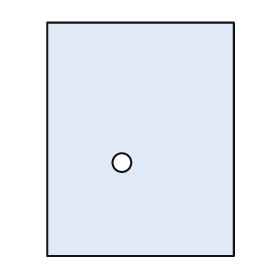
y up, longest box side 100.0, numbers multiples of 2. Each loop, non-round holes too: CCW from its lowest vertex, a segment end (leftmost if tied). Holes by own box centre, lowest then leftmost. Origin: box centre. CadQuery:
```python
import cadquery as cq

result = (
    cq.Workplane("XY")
    .moveTo(-40.0, -50.0)
    .lineTo(40.0, -50.0)
    .lineTo(40.0, 50.0)
    .lineTo(-40.0, 50.0)
    .close()
    .moveTo(-8.0, -10.0)
    .circle(4.0)
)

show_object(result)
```